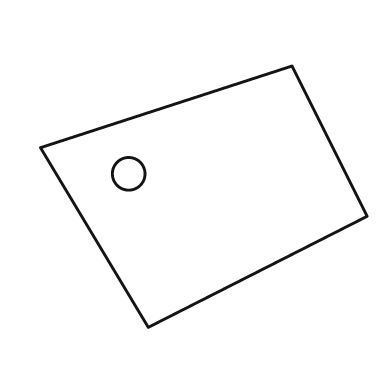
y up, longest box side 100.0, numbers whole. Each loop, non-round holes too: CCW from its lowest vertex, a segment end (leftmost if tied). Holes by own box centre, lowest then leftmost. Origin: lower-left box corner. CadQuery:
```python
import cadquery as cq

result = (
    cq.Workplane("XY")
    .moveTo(33.0, 0.0)
    .lineTo(100.0, 34.0)
    .lineTo(77.0, 80.0)
    .lineTo(0.0, 55.0)
    .close()
    .moveTo(27.0, 47.0)
    .circle(5.0)
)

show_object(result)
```